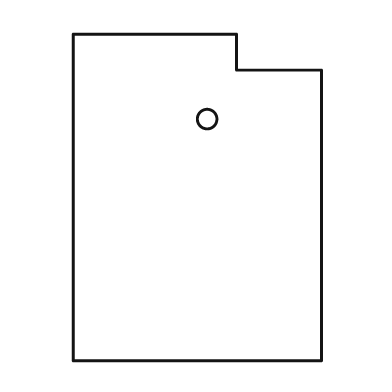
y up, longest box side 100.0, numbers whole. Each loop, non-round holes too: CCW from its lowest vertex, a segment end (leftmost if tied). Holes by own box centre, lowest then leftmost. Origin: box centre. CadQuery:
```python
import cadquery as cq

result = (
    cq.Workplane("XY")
    .moveTo(-38.0, -50.0)
    .lineTo(38.0, -50.0)
    .lineTo(38.0, 39.0)
    .lineTo(12.0, 39.0)
    .lineTo(12.0, 50.0)
    .lineTo(-38.0, 50.0)
    .close()
    .moveTo(3.0, 24.0)
    .circle(3.0)
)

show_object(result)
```